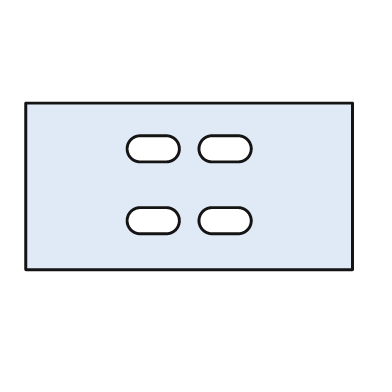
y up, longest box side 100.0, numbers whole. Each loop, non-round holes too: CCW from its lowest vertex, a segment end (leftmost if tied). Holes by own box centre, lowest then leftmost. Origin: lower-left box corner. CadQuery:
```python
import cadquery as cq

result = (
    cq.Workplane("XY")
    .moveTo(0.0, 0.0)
    .lineTo(100.0, 0.0)
    .lineTo(100.0, 51.0)
    .lineTo(0.0, 51.0)
    .close()
    .moveTo(35.0, 11.0)
    .lineTo(43.0, 11.0)
    .threePointArc((47.0, 15.0), (43.0, 19.0))
    .lineTo(35.0, 19.0)
    .threePointArc((31.0, 15.0), (35.0, 11.0))
    .close()
    .moveTo(57.0, 11.0)
    .lineTo(65.0, 11.0)
    .threePointArc((69.0, 15.0), (65.0, 19.0))
    .lineTo(57.0, 19.0)
    .threePointArc((53.0, 15.0), (57.0, 11.0))
    .close()
    .moveTo(35.0, 33.0)
    .lineTo(43.0, 33.0)
    .threePointArc((47.0, 37.0), (43.0, 41.0))
    .lineTo(35.0, 41.0)
    .threePointArc((31.0, 37.0), (35.0, 33.0))
    .close()
    .moveTo(57.0, 33.0)
    .lineTo(65.0, 33.0)
    .threePointArc((69.0, 37.0), (65.0, 41.0))
    .lineTo(57.0, 41.0)
    .threePointArc((53.0, 37.0), (57.0, 33.0))
    .close()
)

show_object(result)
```